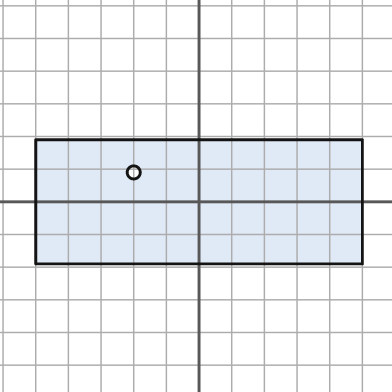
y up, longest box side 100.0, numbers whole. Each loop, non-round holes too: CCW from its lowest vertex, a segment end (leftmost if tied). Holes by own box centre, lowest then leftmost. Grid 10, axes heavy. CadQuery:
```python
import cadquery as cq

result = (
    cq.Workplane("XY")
    .moveTo(-50.0, -19.0)
    .lineTo(50.0, -19.0)
    .lineTo(50.0, 19.0)
    .lineTo(-50.0, 19.0)
    .close()
    .moveTo(-20.0, 9.0)
    .circle(2.0)
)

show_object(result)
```